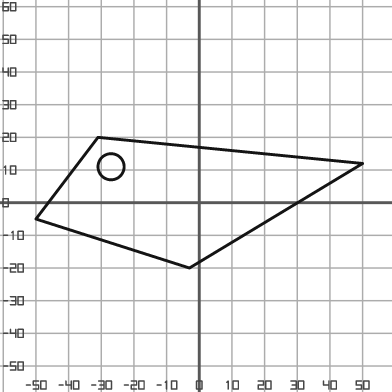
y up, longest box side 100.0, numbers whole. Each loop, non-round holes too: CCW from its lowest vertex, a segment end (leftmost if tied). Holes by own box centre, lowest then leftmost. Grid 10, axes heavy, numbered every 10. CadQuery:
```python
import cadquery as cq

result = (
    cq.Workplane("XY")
    .moveTo(-3.0, -20.0)
    .lineTo(50.0, 12.0)
    .lineTo(-31.0, 20.0)
    .lineTo(-50.0, -5.0)
    .close()
    .moveTo(-27.0, 11.0)
    .circle(4.0)
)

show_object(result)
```